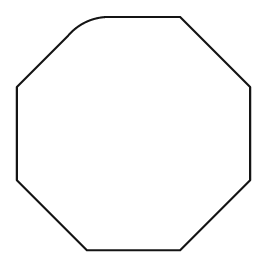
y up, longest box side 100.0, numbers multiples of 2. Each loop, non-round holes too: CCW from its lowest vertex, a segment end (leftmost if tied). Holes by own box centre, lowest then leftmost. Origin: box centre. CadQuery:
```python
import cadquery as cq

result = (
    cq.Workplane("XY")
    .moveTo(-20.0, -50.0)
    .lineTo(20.0, -50.0)
    .lineTo(50.0, -20.0)
    .lineTo(50.0, 20.0)
    .lineTo(20.0, 50.0)
    .lineTo(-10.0, 50.0)
    .threePointArc((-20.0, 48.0), (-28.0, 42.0))
    .lineTo(-50.0, 20.0)
    .lineTo(-50.0, -20.0)
    .close()
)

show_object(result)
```